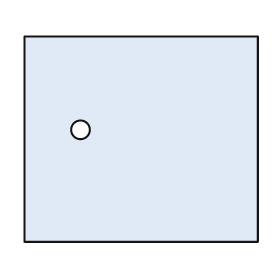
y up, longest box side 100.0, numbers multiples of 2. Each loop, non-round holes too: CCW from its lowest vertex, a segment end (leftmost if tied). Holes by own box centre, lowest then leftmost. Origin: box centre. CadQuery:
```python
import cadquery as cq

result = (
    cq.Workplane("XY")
    .moveTo(-50.0, -44.0)
    .lineTo(50.0, -44.0)
    .lineTo(50.0, 44.0)
    .lineTo(-50.0, 44.0)
    .close()
    .moveTo(-26.0, 4.0)
    .circle(4.0)
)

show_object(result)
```